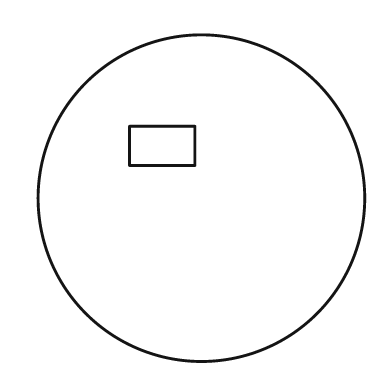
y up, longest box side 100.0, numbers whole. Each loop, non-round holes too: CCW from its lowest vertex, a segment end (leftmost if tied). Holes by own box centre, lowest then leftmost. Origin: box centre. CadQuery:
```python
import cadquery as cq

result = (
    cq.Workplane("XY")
    .moveTo(0.0, 0.0)
    .circle(50.0)
    .moveTo(-22.0, 10.0)
    .lineTo(-2.0, 10.0)
    .lineTo(-2.0, 22.0)
    .lineTo(-22.0, 22.0)
    .close()
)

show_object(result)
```